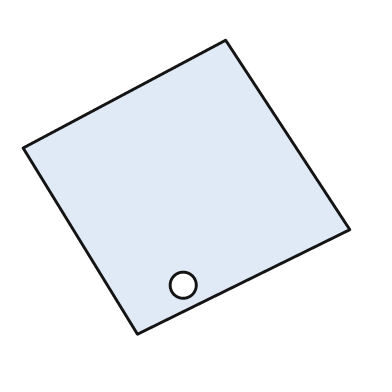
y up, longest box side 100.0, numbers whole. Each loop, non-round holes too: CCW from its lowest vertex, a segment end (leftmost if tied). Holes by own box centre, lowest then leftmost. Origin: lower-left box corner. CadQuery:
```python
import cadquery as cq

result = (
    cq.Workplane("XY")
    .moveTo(35.0, 0.0)
    .lineTo(100.0, 32.0)
    .lineTo(62.0, 90.0)
    .lineTo(0.0, 57.0)
    .close()
    .moveTo(49.0, 15.0)
    .circle(4.0)
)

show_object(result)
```